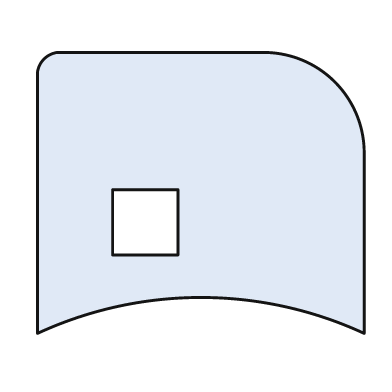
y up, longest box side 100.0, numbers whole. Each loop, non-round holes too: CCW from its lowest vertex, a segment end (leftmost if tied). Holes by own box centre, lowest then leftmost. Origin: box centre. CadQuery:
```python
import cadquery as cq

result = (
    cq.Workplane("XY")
    .moveTo(-50.0, -43.0)
    .threePointArc((0.0, -32.0), (50.0, -43.0))
    .lineTo(50.0, 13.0)
    .threePointArc((41.0, 34.0), (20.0, 43.0))
    .lineTo(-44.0, 43.0)
    .threePointArc((-48.0, 41.0), (-50.0, 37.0))
    .close()
    .moveTo(-27.0, -19.0)
    .lineTo(-7.0, -19.0)
    .lineTo(-7.0, 1.0)
    .lineTo(-27.0, 1.0)
    .close()
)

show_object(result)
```